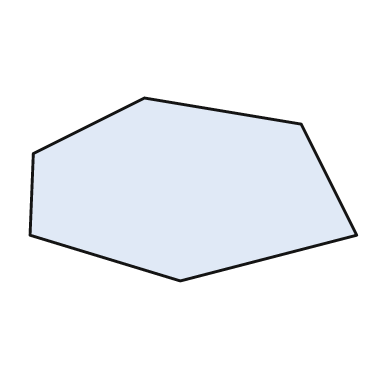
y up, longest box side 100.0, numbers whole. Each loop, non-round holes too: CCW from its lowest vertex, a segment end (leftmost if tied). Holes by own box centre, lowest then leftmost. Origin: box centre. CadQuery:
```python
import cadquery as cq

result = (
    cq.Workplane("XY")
    .moveTo(-4.0, -28.0)
    .lineTo(50.0, -14.0)
    .lineTo(33.0, 20.0)
    .lineTo(-15.0, 28.0)
    .lineTo(-49.0, 11.0)
    .lineTo(-50.0, -14.0)
    .close()
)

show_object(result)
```